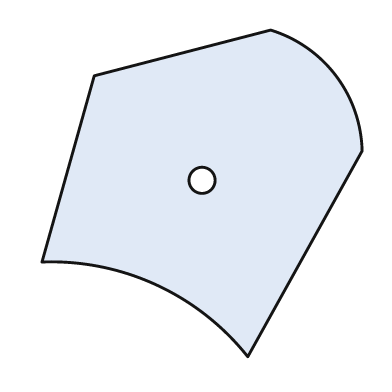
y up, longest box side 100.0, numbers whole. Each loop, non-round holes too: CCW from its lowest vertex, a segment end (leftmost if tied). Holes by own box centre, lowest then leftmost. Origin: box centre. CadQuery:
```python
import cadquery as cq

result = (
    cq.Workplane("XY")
    .moveTo(14.0, -50.0)
    .lineTo(49.0, 13.0)
    .threePointArc((41.0, 36.0), (21.0, 50.0))
    .lineTo(-33.0, 36.0)
    .lineTo(-49.0, -21.0)
    .threePointArc((-14.0, -28.0), (14.0, -50.0))
    .close()
    .moveTo(0.0, 4.0)
    .circle(4.0)
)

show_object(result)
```